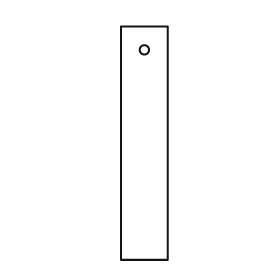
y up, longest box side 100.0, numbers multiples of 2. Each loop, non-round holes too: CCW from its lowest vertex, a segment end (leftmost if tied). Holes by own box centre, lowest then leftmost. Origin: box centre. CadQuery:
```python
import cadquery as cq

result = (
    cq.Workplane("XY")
    .moveTo(-10.0, -50.0)
    .lineTo(10.0, -50.0)
    .lineTo(10.0, 50.0)
    .lineTo(-10.0, 50.0)
    .close()
    .moveTo(0.0, 40.0)
    .circle(2.0)
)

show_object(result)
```